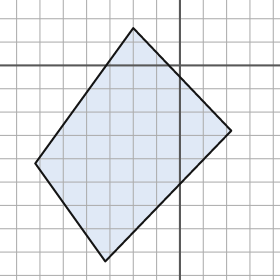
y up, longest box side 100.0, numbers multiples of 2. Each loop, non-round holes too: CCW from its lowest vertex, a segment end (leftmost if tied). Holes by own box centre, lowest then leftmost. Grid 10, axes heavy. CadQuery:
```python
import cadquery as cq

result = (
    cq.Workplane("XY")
    .moveTo(-32.0, -84.0)
    .lineTo(22.0, -28.0)
    .lineTo(-20.0, 16.0)
    .lineTo(-62.0, -42.0)
    .close()
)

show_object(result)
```